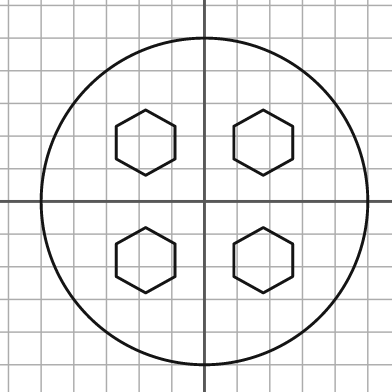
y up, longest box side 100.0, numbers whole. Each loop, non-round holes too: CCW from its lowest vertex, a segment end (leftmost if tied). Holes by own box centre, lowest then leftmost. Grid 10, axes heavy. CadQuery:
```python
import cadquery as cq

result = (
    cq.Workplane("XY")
    .moveTo(0.0, 0.0)
    .circle(50.0)
    .moveTo(-18.0, -28.0)
    .lineTo(-9.0, -23.0)
    .lineTo(-9.0, -13.0)
    .lineTo(-18.0, -8.0)
    .lineTo(-27.0, -13.0)
    .lineTo(-27.0, -23.0)
    .close()
    .moveTo(18.0, -28.0)
    .lineTo(27.0, -23.0)
    .lineTo(27.0, -13.0)
    .lineTo(18.0, -8.0)
    .lineTo(9.0, -13.0)
    .lineTo(9.0, -23.0)
    .close()
    .moveTo(-18.0, 8.0)
    .lineTo(-9.0, 13.0)
    .lineTo(-9.0, 23.0)
    .lineTo(-18.0, 28.0)
    .lineTo(-27.0, 23.0)
    .lineTo(-27.0, 13.0)
    .close()
    .moveTo(18.0, 8.0)
    .lineTo(27.0, 13.0)
    .lineTo(27.0, 23.0)
    .lineTo(18.0, 28.0)
    .lineTo(9.0, 23.0)
    .lineTo(9.0, 13.0)
    .close()
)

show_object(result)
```